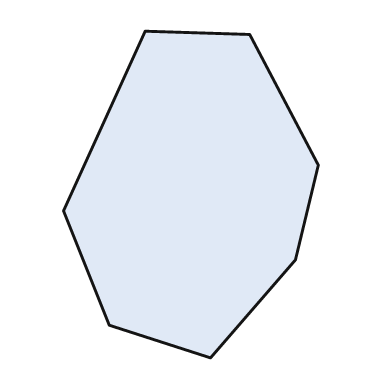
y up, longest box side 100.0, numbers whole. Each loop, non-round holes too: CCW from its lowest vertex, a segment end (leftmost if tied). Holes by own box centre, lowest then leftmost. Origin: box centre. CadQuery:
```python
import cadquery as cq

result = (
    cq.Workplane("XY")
    .moveTo(6.0, -50.0)
    .lineTo(32.0, -20.0)
    .lineTo(39.0, 9.0)
    .lineTo(18.0, 49.0)
    .lineTo(-14.0, 50.0)
    .lineTo(-39.0, -5.0)
    .lineTo(-25.0, -40.0)
    .close()
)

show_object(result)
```